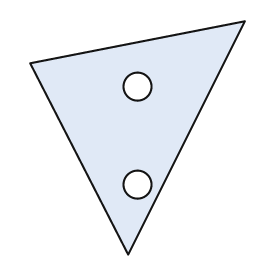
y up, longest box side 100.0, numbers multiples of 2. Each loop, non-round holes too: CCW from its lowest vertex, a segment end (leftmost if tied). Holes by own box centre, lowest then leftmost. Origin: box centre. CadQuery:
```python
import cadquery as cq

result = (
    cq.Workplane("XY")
    .moveTo(-4.0, -50.0)
    .lineTo(46.0, 50.0)
    .lineTo(-46.0, 32.0)
    .close()
    .moveTo(0.0, -20.0)
    .circle(6.0)
    .moveTo(0.0, 22.0)
    .circle(6.0)
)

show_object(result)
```